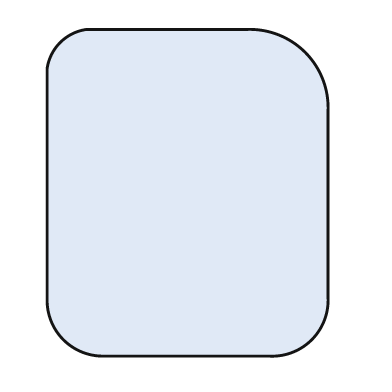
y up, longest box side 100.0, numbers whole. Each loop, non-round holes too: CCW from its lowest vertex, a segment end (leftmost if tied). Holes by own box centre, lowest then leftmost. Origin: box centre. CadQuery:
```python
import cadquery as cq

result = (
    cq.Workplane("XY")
    .moveTo(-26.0, -50.0)
    .lineTo(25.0, -50.0)
    .threePointArc((38.0, -45.0), (43.0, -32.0))
    .lineTo(43.0, 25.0)
    .threePointArc((36.0, 43.0), (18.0, 50.0))
    .lineTo(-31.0, 50.0)
    .threePointArc((-39.0, 46.0), (-43.0, 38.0))
    .lineTo(-43.0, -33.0)
    .threePointArc((-38.0, -45.0), (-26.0, -50.0))
    .close()
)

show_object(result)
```